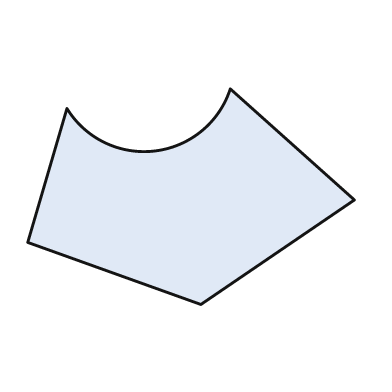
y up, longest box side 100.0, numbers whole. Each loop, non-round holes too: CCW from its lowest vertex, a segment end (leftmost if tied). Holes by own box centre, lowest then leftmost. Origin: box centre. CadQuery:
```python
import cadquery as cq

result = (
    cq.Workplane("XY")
    .moveTo(3.0, -33.0)
    .lineTo(50.0, -1.0)
    .lineTo(12.0, 33.0)
    .threePointArc((-11.0, 14.0), (-38.0, 27.0))
    .lineTo(-50.0, -14.0)
    .close()
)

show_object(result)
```